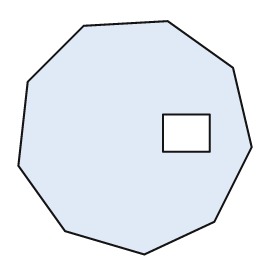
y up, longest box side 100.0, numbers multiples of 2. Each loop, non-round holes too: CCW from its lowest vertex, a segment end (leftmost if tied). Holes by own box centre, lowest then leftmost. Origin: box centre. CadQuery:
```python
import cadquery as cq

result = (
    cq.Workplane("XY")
    .moveTo(4.0, -50.0)
    .lineTo(34.0, -36.0)
    .lineTo(50.0, -4.0)
    .lineTo(42.0, 30.0)
    .lineTo(14.0, 50.0)
    .lineTo(-22.0, 48.0)
    .lineTo(-46.0, 24.0)
    .lineTo(-50.0, -12.0)
    .lineTo(-30.0, -40.0)
    .close()
    .moveTo(12.0, -6.0)
    .lineTo(32.0, -6.0)
    .lineTo(32.0, 10.0)
    .lineTo(12.0, 10.0)
    .close()
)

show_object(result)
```